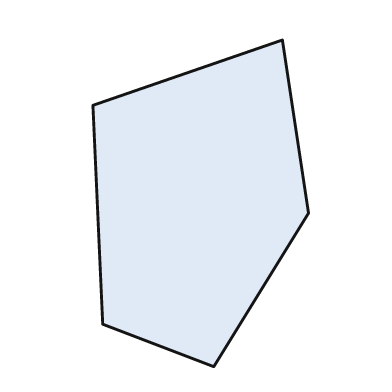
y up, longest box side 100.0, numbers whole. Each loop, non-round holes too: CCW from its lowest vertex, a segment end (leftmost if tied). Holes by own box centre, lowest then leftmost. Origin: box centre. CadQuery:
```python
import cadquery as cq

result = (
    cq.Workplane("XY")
    .moveTo(4.0, -50.0)
    .lineTo(33.0, -3.0)
    .lineTo(25.0, 50.0)
    .lineTo(-33.0, 30.0)
    .lineTo(-30.0, -37.0)
    .close()
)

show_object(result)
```